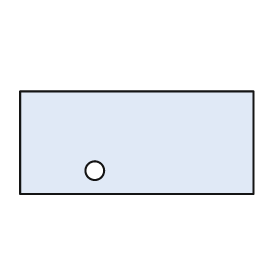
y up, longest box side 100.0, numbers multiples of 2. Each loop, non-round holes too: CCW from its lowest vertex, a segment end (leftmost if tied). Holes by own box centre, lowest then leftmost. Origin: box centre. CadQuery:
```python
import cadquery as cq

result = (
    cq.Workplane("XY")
    .moveTo(-50.0, -22.0)
    .lineTo(50.0, -22.0)
    .lineTo(50.0, 22.0)
    .lineTo(-50.0, 22.0)
    .close()
    .moveTo(-18.0, -12.0)
    .circle(4.0)
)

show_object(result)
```